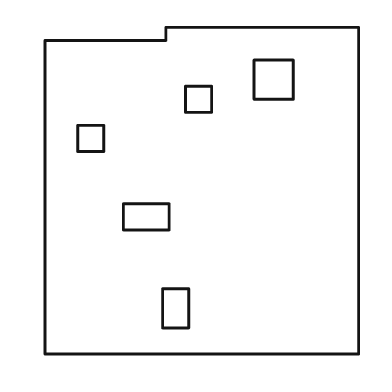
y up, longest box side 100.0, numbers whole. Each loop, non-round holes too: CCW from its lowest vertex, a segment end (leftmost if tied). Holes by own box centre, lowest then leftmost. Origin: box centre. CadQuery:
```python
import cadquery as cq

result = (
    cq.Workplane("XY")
    .moveTo(-48.0, -50.0)
    .lineTo(48.0, -50.0)
    .lineTo(48.0, 50.0)
    .lineTo(-11.0, 50.0)
    .lineTo(-11.0, 46.0)
    .lineTo(-48.0, 46.0)
    .close()
    .moveTo(-12.0, -42.0)
    .lineTo(-4.0, -42.0)
    .lineTo(-4.0, -30.0)
    .lineTo(-12.0, -30.0)
    .close()
    .moveTo(-24.0, -12.0)
    .lineTo(-10.0, -12.0)
    .lineTo(-10.0, -4.0)
    .lineTo(-24.0, -4.0)
    .close()
    .moveTo(-38.0, 12.0)
    .lineTo(-30.0, 12.0)
    .lineTo(-30.0, 20.0)
    .lineTo(-38.0, 20.0)
    .close()
    .moveTo(-5.0, 24.0)
    .lineTo(3.0, 24.0)
    .lineTo(3.0, 32.0)
    .lineTo(-5.0, 32.0)
    .close()
    .moveTo(16.0, 28.0)
    .lineTo(28.0, 28.0)
    .lineTo(28.0, 40.0)
    .lineTo(16.0, 40.0)
    .close()
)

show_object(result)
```